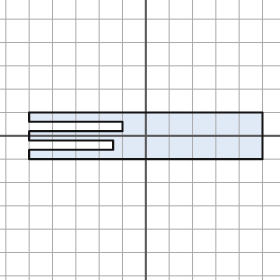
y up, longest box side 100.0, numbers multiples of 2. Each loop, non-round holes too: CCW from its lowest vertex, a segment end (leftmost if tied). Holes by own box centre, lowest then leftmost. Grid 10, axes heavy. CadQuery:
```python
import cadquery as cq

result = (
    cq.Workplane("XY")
    .moveTo(-50.0, -10.0)
    .lineTo(50.0, -10.0)
    .lineTo(50.0, 10.0)
    .lineTo(-50.0, 10.0)
    .lineTo(-50.0, 6.0)
    .lineTo(-10.0, 6.0)
    .lineTo(-10.0, 2.0)
    .lineTo(-50.0, 2.0)
    .lineTo(-50.0, -2.0)
    .lineTo(-14.0, -2.0)
    .lineTo(-14.0, -6.0)
    .lineTo(-50.0, -6.0)
    .close()
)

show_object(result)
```